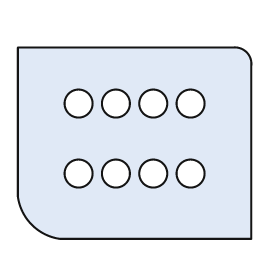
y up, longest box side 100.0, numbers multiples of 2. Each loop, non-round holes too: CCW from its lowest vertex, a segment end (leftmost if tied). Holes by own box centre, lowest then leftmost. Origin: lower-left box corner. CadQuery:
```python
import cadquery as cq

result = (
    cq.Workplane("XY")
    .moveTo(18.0, 0.0)
    .lineTo(100.0, 0.0)
    .lineTo(100.0, 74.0)
    .threePointArc((98.0, 80.0), (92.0, 82.0))
    .lineTo(0.0, 82.0)
    .lineTo(0.0, 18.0)
    .threePointArc((6.0, 6.0), (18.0, 0.0))
    .close()
    .moveTo(26.0, 28.0)
    .circle(6.0)
    .moveTo(42.0, 28.0)
    .circle(6.0)
    .moveTo(58.0, 28.0)
    .circle(6.0)
    .moveTo(74.0, 28.0)
    .circle(6.0)
    .moveTo(26.0, 58.0)
    .circle(6.0)
    .moveTo(42.0, 58.0)
    .circle(6.0)
    .moveTo(58.0, 58.0)
    .circle(6.0)
    .moveTo(74.0, 58.0)
    .circle(6.0)
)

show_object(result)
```